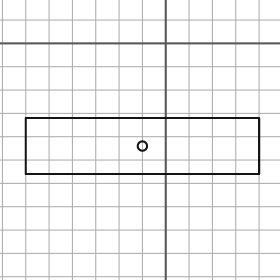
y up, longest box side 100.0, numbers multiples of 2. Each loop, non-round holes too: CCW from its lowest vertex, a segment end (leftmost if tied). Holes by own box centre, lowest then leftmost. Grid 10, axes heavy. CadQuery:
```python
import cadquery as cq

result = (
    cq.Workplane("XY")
    .moveTo(-60.0, -56.0)
    .lineTo(40.0, -56.0)
    .lineTo(40.0, -32.0)
    .lineTo(-60.0, -32.0)
    .close()
    .moveTo(-10.0, -44.0)
    .circle(2.0)
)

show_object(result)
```